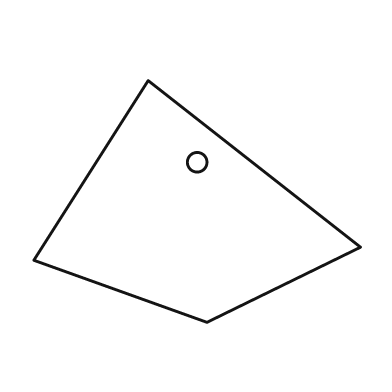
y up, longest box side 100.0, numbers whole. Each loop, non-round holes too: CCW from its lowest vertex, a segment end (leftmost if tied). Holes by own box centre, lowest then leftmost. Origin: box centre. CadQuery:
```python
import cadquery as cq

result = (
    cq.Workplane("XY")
    .moveTo(3.0, -37.0)
    .lineTo(50.0, -14.0)
    .lineTo(-15.0, 37.0)
    .lineTo(-50.0, -18.0)
    .close()
    .moveTo(0.0, 12.0)
    .circle(3.0)
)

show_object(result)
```